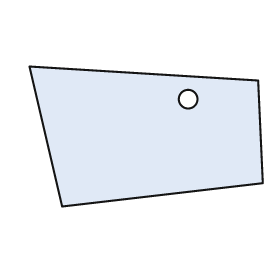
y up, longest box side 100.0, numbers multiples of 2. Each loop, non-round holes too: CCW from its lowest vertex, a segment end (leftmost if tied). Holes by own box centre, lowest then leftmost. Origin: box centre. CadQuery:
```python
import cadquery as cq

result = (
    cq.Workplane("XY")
    .moveTo(-36.0, -30.0)
    .lineTo(50.0, -20.0)
    .lineTo(48.0, 24.0)
    .lineTo(-50.0, 30.0)
    .close()
    .moveTo(18.0, 16.0)
    .circle(4.0)
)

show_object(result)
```